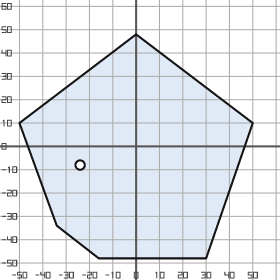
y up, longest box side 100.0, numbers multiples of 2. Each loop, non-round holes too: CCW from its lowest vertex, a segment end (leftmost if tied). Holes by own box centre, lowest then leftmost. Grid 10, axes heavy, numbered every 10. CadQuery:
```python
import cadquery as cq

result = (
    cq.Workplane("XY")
    .moveTo(-16.0, -48.0)
    .lineTo(30.0, -48.0)
    .lineTo(50.0, 10.0)
    .lineTo(0.0, 48.0)
    .lineTo(-50.0, 10.0)
    .lineTo(-34.0, -34.0)
    .close()
    .moveTo(-24.0, -8.0)
    .circle(2.0)
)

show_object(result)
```